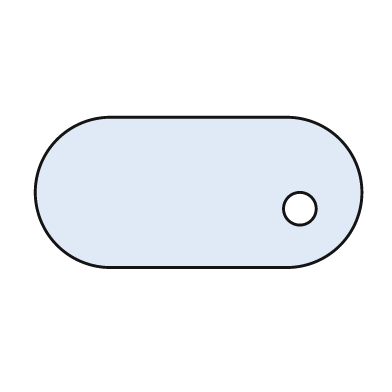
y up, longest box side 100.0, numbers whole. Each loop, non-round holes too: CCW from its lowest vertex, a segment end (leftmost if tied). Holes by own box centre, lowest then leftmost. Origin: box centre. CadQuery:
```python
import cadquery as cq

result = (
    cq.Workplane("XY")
    .moveTo(-27.0, -23.0)
    .lineTo(27.0, -23.0)
    .threePointArc((50.0, 0.0), (27.0, 23.0))
    .lineTo(-27.0, 23.0)
    .threePointArc((-50.0, 0.0), (-27.0, -23.0))
    .close()
    .moveTo(31.0, -5.0)
    .circle(5.0)
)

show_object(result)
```